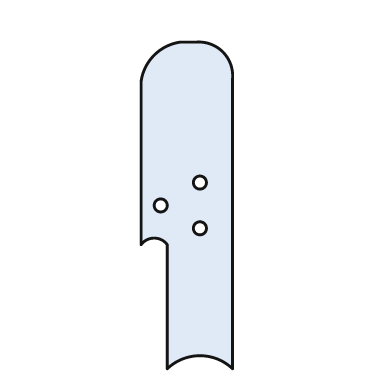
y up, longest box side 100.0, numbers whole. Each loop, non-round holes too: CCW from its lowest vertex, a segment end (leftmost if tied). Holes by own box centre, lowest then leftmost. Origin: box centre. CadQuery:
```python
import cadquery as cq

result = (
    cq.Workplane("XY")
    .moveTo(-6.0, -50.0)
    .threePointArc((4.0, -46.0), (14.0, -50.0))
    .lineTo(14.0, 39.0)
    .threePointArc((11.0, 47.0), (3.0, 50.0))
    .lineTo(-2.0, 50.0)
    .threePointArc((-10.0, 46.0), (-14.0, 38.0))
    .lineTo(-14.0, -12.0)
    .threePointArc((-10.0, -10.0), (-6.0, -12.0))
    .close()
    .moveTo(4.0, -7.0)
    .circle(2.0)
    .moveTo(-8.0, 0.0)
    .circle(2.0)
    .moveTo(4.0, 7.0)
    .circle(2.0)
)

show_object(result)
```